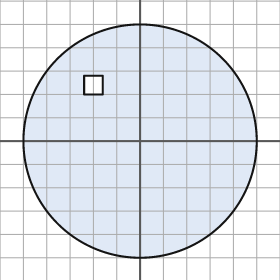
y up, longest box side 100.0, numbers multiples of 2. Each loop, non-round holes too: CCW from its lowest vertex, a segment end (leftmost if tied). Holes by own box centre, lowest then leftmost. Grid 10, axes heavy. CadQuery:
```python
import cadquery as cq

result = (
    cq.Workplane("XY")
    .moveTo(0.0, 0.0)
    .circle(50.0)
    .moveTo(-24.0, 20.0)
    .lineTo(-16.0, 20.0)
    .lineTo(-16.0, 28.0)
    .lineTo(-24.0, 28.0)
    .close()
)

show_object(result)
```